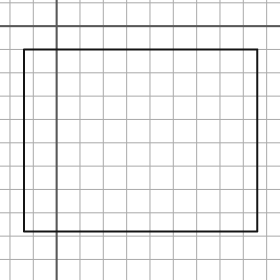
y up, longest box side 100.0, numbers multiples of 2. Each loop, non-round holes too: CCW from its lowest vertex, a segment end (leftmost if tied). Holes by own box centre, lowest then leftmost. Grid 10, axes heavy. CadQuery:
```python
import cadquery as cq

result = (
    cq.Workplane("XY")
    .moveTo(-14.0, -88.0)
    .lineTo(86.0, -88.0)
    .lineTo(86.0, -10.0)
    .lineTo(-14.0, -10.0)
    .close()
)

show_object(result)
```